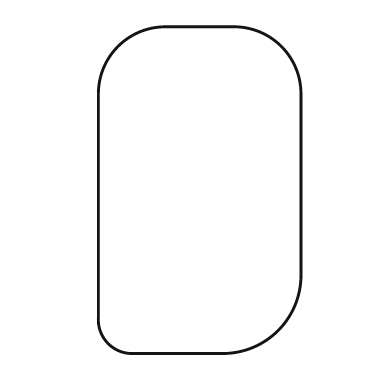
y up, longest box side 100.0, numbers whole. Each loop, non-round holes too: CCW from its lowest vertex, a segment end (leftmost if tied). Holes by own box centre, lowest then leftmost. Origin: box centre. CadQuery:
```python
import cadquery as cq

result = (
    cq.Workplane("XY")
    .moveTo(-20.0, -50.0)
    .lineTo(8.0, -50.0)
    .threePointArc((24.0, -43.0), (31.0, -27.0))
    .lineTo(31.0, 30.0)
    .threePointArc((25.0, 44.0), (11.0, 50.0))
    .lineTo(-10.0, 50.0)
    .threePointArc((-25.0, 44.0), (-31.0, 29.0))
    .lineTo(-31.0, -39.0)
    .threePointArc((-28.0, -47.0), (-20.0, -50.0))
    .close()
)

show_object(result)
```